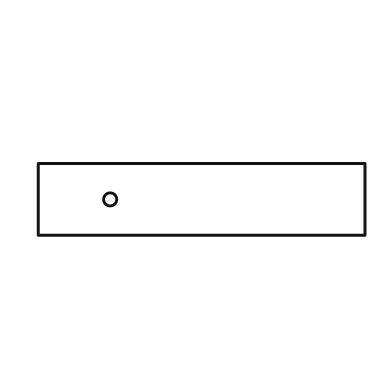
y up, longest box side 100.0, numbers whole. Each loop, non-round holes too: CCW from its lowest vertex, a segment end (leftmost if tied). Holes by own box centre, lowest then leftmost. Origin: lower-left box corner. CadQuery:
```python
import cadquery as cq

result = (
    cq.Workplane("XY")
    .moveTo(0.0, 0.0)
    .lineTo(100.0, 0.0)
    .lineTo(100.0, 22.0)
    .lineTo(0.0, 22.0)
    .close()
    .moveTo(22.0, 11.0)
    .circle(2.0)
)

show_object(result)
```